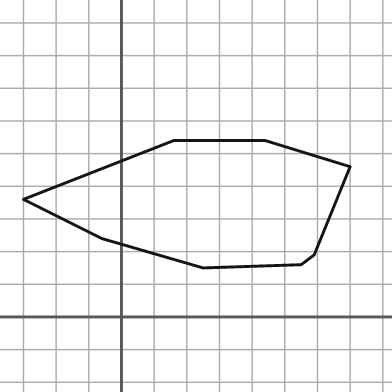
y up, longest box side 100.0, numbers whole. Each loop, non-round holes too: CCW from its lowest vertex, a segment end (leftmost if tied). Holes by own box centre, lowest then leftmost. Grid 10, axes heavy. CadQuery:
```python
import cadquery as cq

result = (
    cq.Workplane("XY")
    .moveTo(25.0, 15.0)
    .lineTo(55.0, 16.0)
    .lineTo(59.0, 19.0)
    .lineTo(70.0, 46.0)
    .lineTo(44.0, 54.0)
    .lineTo(16.0, 54.0)
    .lineTo(-30.0, 36.0)
    .lineTo(-6.0, 24.0)
    .close()
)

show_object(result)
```